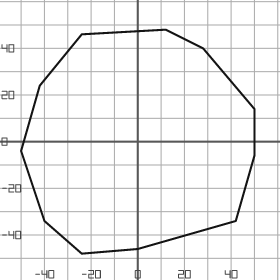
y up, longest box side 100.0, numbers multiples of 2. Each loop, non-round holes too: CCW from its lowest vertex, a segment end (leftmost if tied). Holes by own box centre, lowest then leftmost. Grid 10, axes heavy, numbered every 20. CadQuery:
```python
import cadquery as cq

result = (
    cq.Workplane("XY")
    .moveTo(-24.0, -48.0)
    .lineTo(0.0, -46.0)
    .lineTo(42.0, -34.0)
    .lineTo(50.0, -6.0)
    .lineTo(50.0, 14.0)
    .lineTo(28.0, 40.0)
    .lineTo(12.0, 48.0)
    .lineTo(-24.0, 46.0)
    .lineTo(-42.0, 24.0)
    .lineTo(-50.0, -4.0)
    .lineTo(-40.0, -34.0)
    .close()
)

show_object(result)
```